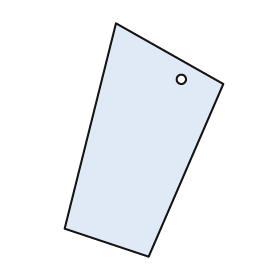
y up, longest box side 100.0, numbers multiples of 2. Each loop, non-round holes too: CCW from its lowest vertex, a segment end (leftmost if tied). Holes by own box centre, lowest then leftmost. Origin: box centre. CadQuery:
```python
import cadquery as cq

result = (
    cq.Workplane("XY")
    .moveTo(2.0, -50.0)
    .lineTo(34.0, 24.0)
    .lineTo(-12.0, 50.0)
    .lineTo(-34.0, -38.0)
    .close()
    .moveTo(16.0, 26.0)
    .circle(2.0)
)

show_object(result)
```